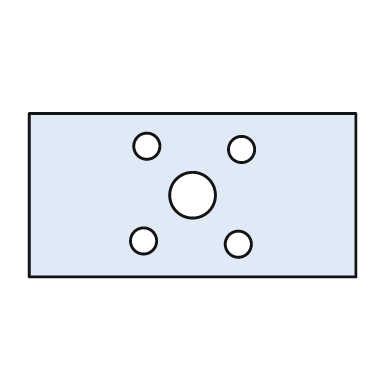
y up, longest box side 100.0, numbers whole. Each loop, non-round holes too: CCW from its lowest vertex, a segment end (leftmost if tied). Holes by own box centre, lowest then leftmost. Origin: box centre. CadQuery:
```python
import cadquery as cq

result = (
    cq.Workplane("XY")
    .moveTo(-50.0, -25.0)
    .lineTo(50.0, -25.0)
    .lineTo(50.0, 25.0)
    .lineTo(-50.0, 25.0)
    .close()
    .moveTo(14.0, -15.0)
    .circle(4.0)
    .moveTo(-15.0, -14.0)
    .circle(4.0)
    .moveTo(0.0, 0.0)
    .circle(7.0)
    .moveTo(15.0, 14.0)
    .circle(4.0)
    .moveTo(-14.0, 15.0)
    .circle(4.0)
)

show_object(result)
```